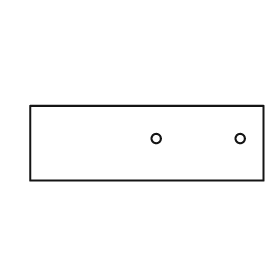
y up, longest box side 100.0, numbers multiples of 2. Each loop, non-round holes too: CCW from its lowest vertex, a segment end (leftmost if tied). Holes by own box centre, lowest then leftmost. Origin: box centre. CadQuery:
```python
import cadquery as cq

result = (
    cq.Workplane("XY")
    .moveTo(-50.0, -16.0)
    .lineTo(50.0, -16.0)
    .lineTo(50.0, 16.0)
    .lineTo(-50.0, 16.0)
    .close()
    .moveTo(4.0, 2.0)
    .circle(2.0)
    .moveTo(40.0, 2.0)
    .circle(2.0)
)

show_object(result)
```